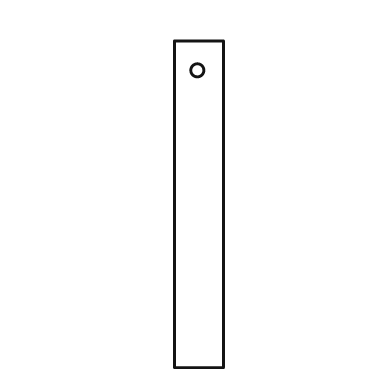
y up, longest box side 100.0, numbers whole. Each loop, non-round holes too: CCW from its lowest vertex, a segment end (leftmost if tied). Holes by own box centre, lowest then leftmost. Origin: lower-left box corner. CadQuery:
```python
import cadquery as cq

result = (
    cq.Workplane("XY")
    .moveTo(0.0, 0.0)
    .lineTo(15.0, 0.0)
    .lineTo(15.0, 100.0)
    .lineTo(0.0, 100.0)
    .close()
    .moveTo(7.0, 91.0)
    .circle(2.0)
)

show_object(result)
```